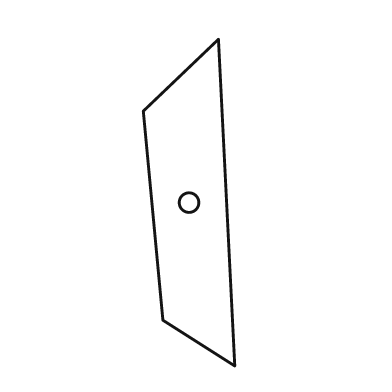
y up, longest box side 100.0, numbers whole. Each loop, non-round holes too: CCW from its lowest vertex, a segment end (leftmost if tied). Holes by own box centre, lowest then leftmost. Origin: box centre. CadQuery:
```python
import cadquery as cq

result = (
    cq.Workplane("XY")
    .moveTo(14.0, -50.0)
    .lineTo(9.0, 50.0)
    .lineTo(-14.0, 28.0)
    .lineTo(-8.0, -36.0)
    .close()
    .moveTo(0.0, 0.0)
    .circle(3.0)
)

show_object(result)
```